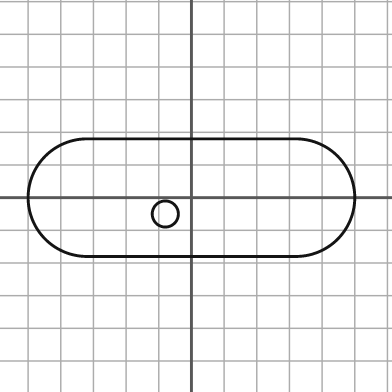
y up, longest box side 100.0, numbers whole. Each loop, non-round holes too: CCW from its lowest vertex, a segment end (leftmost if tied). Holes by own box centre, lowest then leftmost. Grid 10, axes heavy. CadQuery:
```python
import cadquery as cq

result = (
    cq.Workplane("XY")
    .moveTo(-32.0, -18.0)
    .lineTo(32.0, -18.0)
    .threePointArc((50.0, 0.0), (32.0, 18.0))
    .lineTo(-32.0, 18.0)
    .threePointArc((-50.0, 0.0), (-32.0, -18.0))
    .close()
    .moveTo(-8.0, -5.0)
    .circle(4.0)
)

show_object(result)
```